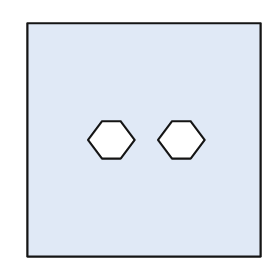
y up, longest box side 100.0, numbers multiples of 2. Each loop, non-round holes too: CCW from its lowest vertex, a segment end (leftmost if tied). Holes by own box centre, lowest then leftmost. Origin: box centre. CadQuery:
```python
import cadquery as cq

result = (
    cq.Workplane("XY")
    .moveTo(-50.0, -50.0)
    .lineTo(50.0, -50.0)
    .lineTo(50.0, 50.0)
    .lineTo(-50.0, 50.0)
    .close()
    .moveTo(-18.0, -8.0)
    .lineTo(-10.0, -8.0)
    .lineTo(-4.0, 0.0)
    .lineTo(-10.0, 8.0)
    .lineTo(-18.0, 8.0)
    .lineTo(-24.0, 0.0)
    .close()
    .moveTo(12.0, -8.0)
    .lineTo(20.0, -8.0)
    .lineTo(26.0, 0.0)
    .lineTo(20.0, 8.0)
    .lineTo(12.0, 8.0)
    .lineTo(6.0, 0.0)
    .close()
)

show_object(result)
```